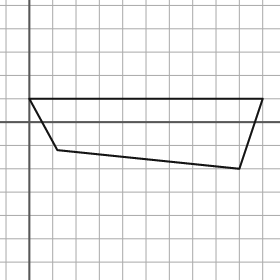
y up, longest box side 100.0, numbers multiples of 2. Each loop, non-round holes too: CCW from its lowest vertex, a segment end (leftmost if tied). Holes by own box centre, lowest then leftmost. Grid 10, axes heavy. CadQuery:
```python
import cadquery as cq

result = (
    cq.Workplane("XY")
    .moveTo(90.0, -20.0)
    .lineTo(100.0, 10.0)
    .lineTo(0.0, 10.0)
    .lineTo(12.0, -12.0)
    .close()
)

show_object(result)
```